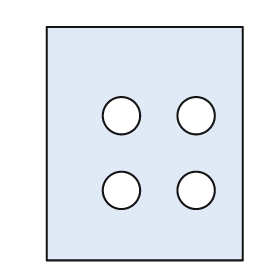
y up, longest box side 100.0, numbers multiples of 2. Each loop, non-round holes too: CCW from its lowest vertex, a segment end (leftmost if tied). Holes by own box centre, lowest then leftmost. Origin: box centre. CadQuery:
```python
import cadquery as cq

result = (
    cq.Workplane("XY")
    .moveTo(-42.0, -50.0)
    .lineTo(42.0, -50.0)
    .lineTo(42.0, 50.0)
    .lineTo(-42.0, 50.0)
    .close()
    .moveTo(-10.0, -20.0)
    .circle(8.0)
    .moveTo(22.0, -20.0)
    .circle(8.0)
    .moveTo(-10.0, 12.0)
    .circle(8.0)
    .moveTo(22.0, 12.0)
    .circle(8.0)
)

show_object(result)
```